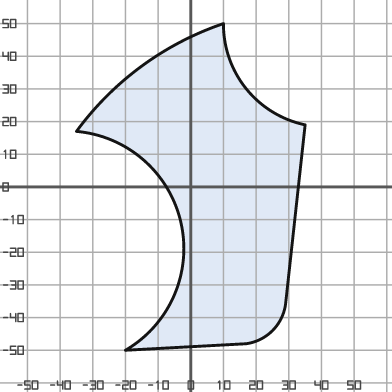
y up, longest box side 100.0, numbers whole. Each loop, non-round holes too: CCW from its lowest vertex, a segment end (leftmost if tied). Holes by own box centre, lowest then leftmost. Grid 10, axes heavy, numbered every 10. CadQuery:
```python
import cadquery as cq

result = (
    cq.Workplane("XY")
    .moveTo(-20.0, -50.0)
    .lineTo(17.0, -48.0)
    .threePointArc((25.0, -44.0), (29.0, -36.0))
    .lineTo(35.0, 19.0)
    .threePointArc((17.0, 30.0), (10.0, 50.0))
    .threePointArc((-15.0, 37.0), (-35.0, 17.0))
    .threePointArc((-3.0, -11.0), (-20.0, -50.0))
    .close()
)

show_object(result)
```